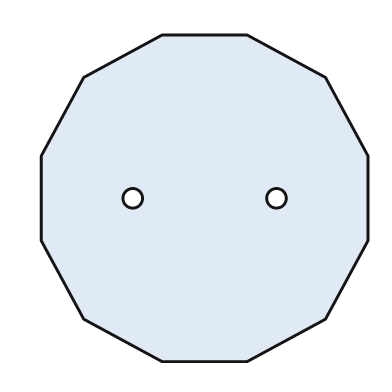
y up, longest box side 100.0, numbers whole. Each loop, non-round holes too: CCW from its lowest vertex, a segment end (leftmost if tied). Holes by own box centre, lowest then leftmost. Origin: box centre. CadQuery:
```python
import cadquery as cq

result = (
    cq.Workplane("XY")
    .moveTo(-13.0, -50.0)
    .lineTo(13.0, -50.0)
    .lineTo(37.0, -37.0)
    .lineTo(50.0, -13.0)
    .lineTo(50.0, 13.0)
    .lineTo(37.0, 37.0)
    .lineTo(13.0, 50.0)
    .lineTo(-13.0, 50.0)
    .lineTo(-37.0, 37.0)
    .lineTo(-50.0, 13.0)
    .lineTo(-50.0, -13.0)
    .lineTo(-37.0, -37.0)
    .close()
    .moveTo(-22.0, 0.0)
    .circle(3.0)
    .moveTo(22.0, 0.0)
    .circle(3.0)
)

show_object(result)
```